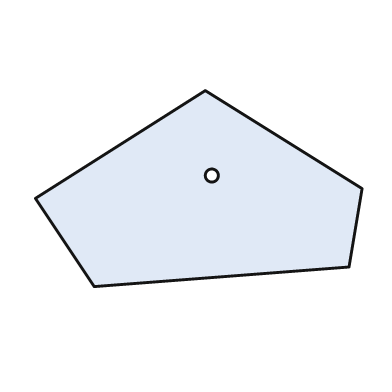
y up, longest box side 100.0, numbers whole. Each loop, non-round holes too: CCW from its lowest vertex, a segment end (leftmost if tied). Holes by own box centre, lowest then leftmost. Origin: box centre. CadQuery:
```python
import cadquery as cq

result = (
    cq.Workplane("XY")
    .moveTo(-32.0, -30.0)
    .lineTo(46.0, -24.0)
    .lineTo(50.0, 0.0)
    .lineTo(2.0, 30.0)
    .lineTo(-50.0, -3.0)
    .close()
    .moveTo(4.0, 4.0)
    .circle(2.0)
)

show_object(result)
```